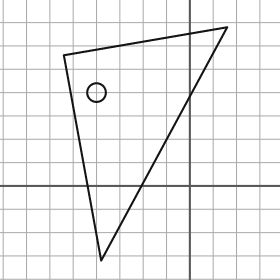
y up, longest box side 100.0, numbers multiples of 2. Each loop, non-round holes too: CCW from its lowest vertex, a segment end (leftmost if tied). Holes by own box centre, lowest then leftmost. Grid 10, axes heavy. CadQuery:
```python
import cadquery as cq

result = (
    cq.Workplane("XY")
    .moveTo(-38.0, -32.0)
    .lineTo(16.0, 68.0)
    .lineTo(-54.0, 56.0)
    .close()
    .moveTo(-40.0, 40.0)
    .circle(4.0)
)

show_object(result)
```